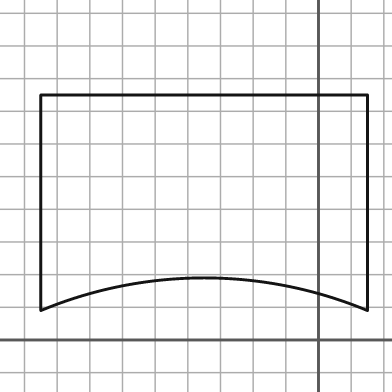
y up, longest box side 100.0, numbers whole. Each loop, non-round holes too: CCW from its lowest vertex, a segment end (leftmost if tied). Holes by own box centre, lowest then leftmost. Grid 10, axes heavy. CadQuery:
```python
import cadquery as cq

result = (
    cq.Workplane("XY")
    .moveTo(-85.0, 9.0)
    .threePointArc((-35.0, 19.0), (15.0, 9.0))
    .lineTo(15.0, 75.0)
    .lineTo(-85.0, 75.0)
    .close()
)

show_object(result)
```